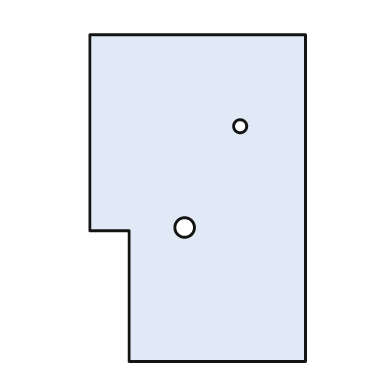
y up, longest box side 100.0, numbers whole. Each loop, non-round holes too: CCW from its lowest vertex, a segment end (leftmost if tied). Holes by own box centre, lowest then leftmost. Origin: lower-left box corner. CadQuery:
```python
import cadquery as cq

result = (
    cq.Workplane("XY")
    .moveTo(12.0, 0.0)
    .lineTo(66.0, 0.0)
    .lineTo(66.0, 100.0)
    .lineTo(0.0, 100.0)
    .lineTo(0.0, 40.0)
    .lineTo(12.0, 40.0)
    .close()
    .moveTo(29.0, 41.0)
    .circle(3.0)
    .moveTo(46.0, 72.0)
    .circle(2.0)
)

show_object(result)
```